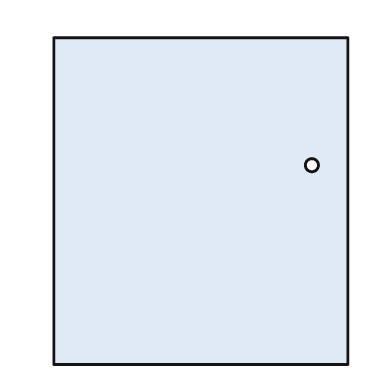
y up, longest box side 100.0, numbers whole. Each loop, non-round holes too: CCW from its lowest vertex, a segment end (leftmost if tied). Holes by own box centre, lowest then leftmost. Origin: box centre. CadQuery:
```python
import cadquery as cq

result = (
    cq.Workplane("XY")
    .moveTo(-45.0, -50.0)
    .lineTo(45.0, -50.0)
    .lineTo(45.0, 50.0)
    .lineTo(-45.0, 50.0)
    .close()
    .moveTo(34.0, 11.0)
    .circle(2.0)
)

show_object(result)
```